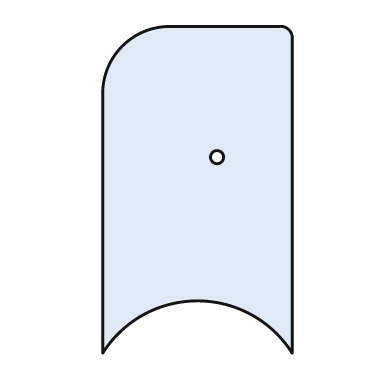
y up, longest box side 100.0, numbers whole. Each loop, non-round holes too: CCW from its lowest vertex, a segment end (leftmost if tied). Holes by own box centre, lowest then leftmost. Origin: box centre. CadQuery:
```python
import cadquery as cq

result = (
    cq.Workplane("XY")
    .moveTo(-29.0, -50.0)
    .threePointArc((0.0, -34.0), (29.0, -50.0))
    .lineTo(29.0, 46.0)
    .threePointArc((28.0, 49.0), (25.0, 50.0))
    .lineTo(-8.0, 50.0)
    .threePointArc((-23.0, 44.0), (-29.0, 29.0))
    .close()
    .moveTo(6.0, 10.0)
    .circle(2.0)
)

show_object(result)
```